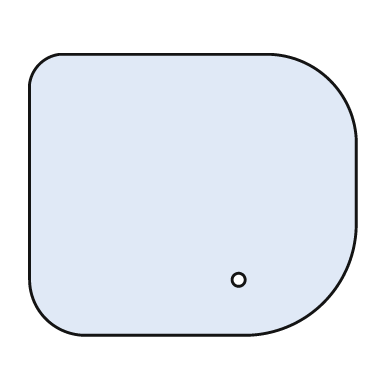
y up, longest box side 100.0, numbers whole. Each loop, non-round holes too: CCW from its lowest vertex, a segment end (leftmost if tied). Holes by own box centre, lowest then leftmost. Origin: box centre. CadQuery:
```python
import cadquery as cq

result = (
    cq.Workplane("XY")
    .moveTo(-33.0, -43.0)
    .lineTo(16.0, -43.0)
    .threePointArc((40.0, -33.0), (50.0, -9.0))
    .lineTo(50.0, 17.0)
    .threePointArc((42.0, 35.0), (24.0, 43.0))
    .lineTo(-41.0, 43.0)
    .threePointArc((-47.0, 40.0), (-50.0, 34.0))
    .lineTo(-50.0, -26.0)
    .threePointArc((-45.0, -38.0), (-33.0, -43.0))
    .close()
    .moveTo(14.0, -26.0)
    .circle(2.0)
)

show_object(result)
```